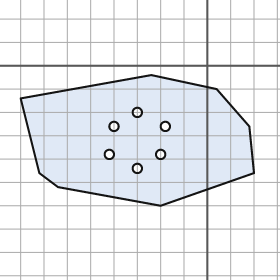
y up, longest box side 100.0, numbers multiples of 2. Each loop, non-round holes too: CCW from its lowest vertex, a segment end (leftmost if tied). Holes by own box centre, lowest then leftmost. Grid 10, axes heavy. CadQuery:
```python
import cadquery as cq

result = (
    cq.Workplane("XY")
    .moveTo(-20.0, -60.0)
    .lineTo(20.0, -46.0)
    .lineTo(18.0, -26.0)
    .lineTo(4.0, -10.0)
    .lineTo(-24.0, -4.0)
    .lineTo(-80.0, -14.0)
    .lineTo(-72.0, -46.0)
    .lineTo(-64.0, -52.0)
    .close()
    .moveTo(-30.0, -44.0)
    .circle(2.0)
    .moveTo(-42.0, -38.0)
    .circle(2.0)
    .moveTo(-20.0, -38.0)
    .circle(2.0)
    .moveTo(-40.0, -26.0)
    .circle(2.0)
    .moveTo(-18.0, -26.0)
    .circle(2.0)
    .moveTo(-30.0, -20.0)
    .circle(2.0)
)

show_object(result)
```